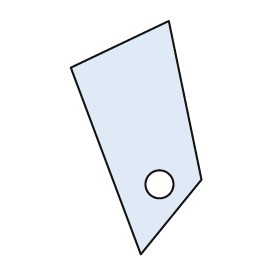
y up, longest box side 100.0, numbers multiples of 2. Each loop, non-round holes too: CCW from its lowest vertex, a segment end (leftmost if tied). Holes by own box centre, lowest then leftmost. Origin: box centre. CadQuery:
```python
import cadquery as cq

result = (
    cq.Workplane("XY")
    .moveTo(2.0, -50.0)
    .lineTo(28.0, -18.0)
    .lineTo(14.0, 50.0)
    .lineTo(-28.0, 30.0)
    .close()
    .moveTo(10.0, -20.0)
    .circle(6.0)
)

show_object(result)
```